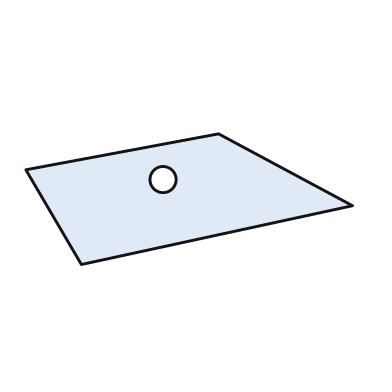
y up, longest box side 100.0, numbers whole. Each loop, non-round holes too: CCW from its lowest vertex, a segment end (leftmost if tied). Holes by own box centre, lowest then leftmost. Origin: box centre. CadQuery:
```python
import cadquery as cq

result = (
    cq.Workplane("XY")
    .moveTo(-33.0, -20.0)
    .lineTo(50.0, -2.0)
    .lineTo(9.0, 20.0)
    .lineTo(-50.0, 9.0)
    .close()
    .moveTo(-8.0, 6.0)
    .circle(4.0)
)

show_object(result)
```